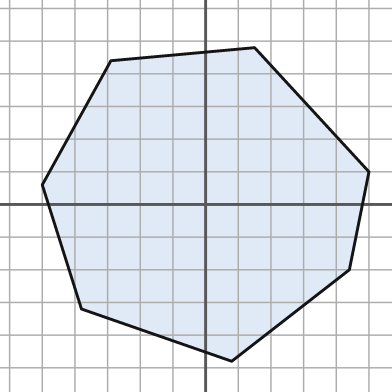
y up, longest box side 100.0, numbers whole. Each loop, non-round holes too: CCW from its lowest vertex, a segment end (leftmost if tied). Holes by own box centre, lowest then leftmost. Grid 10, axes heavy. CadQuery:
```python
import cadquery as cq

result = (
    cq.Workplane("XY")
    .moveTo(8.0, -48.0)
    .lineTo(44.0, -20.0)
    .lineTo(50.0, 10.0)
    .lineTo(15.0, 48.0)
    .lineTo(-29.0, 44.0)
    .lineTo(-50.0, 6.0)
    .lineTo(-38.0, -32.0)
    .close()
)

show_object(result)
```